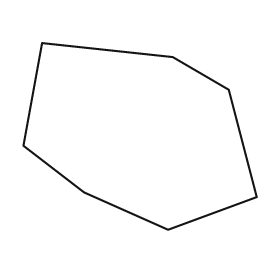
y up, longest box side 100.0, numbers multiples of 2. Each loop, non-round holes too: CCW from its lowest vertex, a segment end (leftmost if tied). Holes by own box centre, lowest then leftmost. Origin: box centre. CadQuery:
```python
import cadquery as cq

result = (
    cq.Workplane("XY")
    .moveTo(12.0, -40.0)
    .lineTo(50.0, -26.0)
    .lineTo(38.0, 20.0)
    .lineTo(14.0, 34.0)
    .lineTo(-42.0, 40.0)
    .lineTo(-50.0, -4.0)
    .lineTo(-24.0, -24.0)
    .close()
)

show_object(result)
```